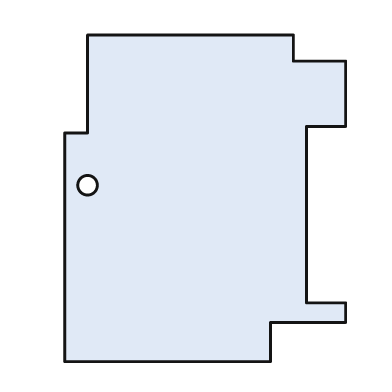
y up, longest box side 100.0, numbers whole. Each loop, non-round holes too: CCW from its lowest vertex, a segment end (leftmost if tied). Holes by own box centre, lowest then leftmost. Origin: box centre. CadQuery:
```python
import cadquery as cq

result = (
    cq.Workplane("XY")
    .moveTo(-43.0, -50.0)
    .lineTo(20.0, -50.0)
    .lineTo(20.0, -38.0)
    .lineTo(43.0, -38.0)
    .lineTo(43.0, -32.0)
    .lineTo(31.0, -32.0)
    .lineTo(31.0, 22.0)
    .lineTo(43.0, 22.0)
    .lineTo(43.0, 42.0)
    .lineTo(27.0, 42.0)
    .lineTo(27.0, 50.0)
    .lineTo(-36.0, 50.0)
    .lineTo(-36.0, 20.0)
    .lineTo(-43.0, 20.0)
    .close()
    .moveTo(-36.0, 4.0)
    .circle(3.0)
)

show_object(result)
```